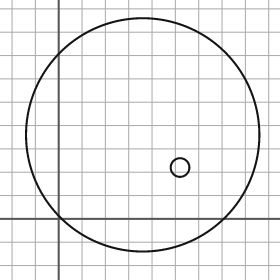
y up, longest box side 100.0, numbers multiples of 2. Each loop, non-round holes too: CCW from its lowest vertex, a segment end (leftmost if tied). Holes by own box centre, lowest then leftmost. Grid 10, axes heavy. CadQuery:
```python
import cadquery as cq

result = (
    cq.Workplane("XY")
    .moveTo(36.0, 36.0)
    .circle(50.0)
    .moveTo(52.0, 22.0)
    .circle(4.0)
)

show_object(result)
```